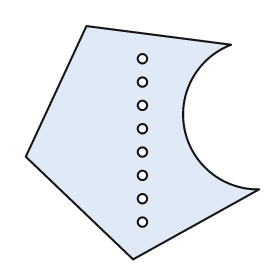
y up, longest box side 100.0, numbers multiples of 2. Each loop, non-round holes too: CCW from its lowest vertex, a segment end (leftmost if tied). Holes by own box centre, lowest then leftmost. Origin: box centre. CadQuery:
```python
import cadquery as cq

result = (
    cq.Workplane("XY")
    .moveTo(-4.0, -50.0)
    .lineTo(50.0, -20.0)
    .threePointArc((18.0, 6.0), (38.0, 42.0))
    .lineTo(-24.0, 50.0)
    .lineTo(-50.0, -6.0)
    .close()
    .moveTo(0.0, -34.0)
    .circle(2.0)
    .moveTo(0.0, -24.0)
    .circle(2.0)
    .moveTo(0.0, -14.0)
    .circle(2.0)
    .moveTo(0.0, -4.0)
    .circle(2.0)
    .moveTo(0.0, 6.0)
    .circle(2.0)
    .moveTo(0.0, 16.0)
    .circle(2.0)
    .moveTo(0.0, 26.0)
    .circle(2.0)
    .moveTo(0.0, 36.0)
    .circle(2.0)
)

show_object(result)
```